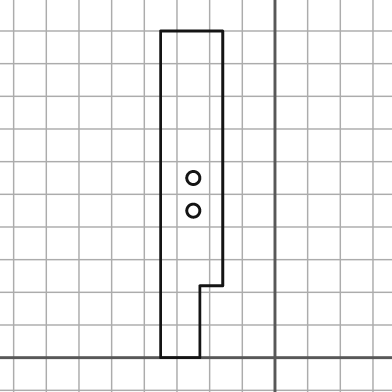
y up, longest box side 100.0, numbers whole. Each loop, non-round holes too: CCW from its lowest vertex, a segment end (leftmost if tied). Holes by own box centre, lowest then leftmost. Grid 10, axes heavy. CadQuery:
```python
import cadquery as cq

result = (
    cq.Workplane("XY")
    .moveTo(-35.0, 0.0)
    .lineTo(-23.0, 0.0)
    .lineTo(-23.0, 22.0)
    .lineTo(-16.0, 22.0)
    .lineTo(-16.0, 100.0)
    .lineTo(-35.0, 100.0)
    .close()
    .moveTo(-25.0, 45.0)
    .circle(2.0)
    .moveTo(-25.0, 55.0)
    .circle(2.0)
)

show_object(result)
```